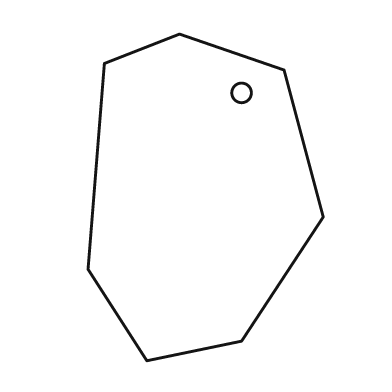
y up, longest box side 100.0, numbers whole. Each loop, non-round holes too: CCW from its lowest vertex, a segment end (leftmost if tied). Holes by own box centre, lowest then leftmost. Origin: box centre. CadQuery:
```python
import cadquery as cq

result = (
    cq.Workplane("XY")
    .moveTo(-18.0, -50.0)
    .lineTo(11.0, -44.0)
    .lineTo(36.0, -6.0)
    .lineTo(24.0, 39.0)
    .lineTo(-8.0, 50.0)
    .lineTo(-31.0, 41.0)
    .lineTo(-36.0, -22.0)
    .close()
    .moveTo(11.0, 32.0)
    .circle(3.0)
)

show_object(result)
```